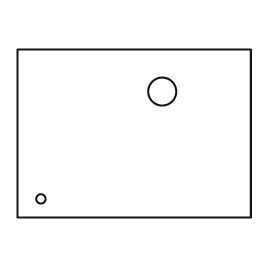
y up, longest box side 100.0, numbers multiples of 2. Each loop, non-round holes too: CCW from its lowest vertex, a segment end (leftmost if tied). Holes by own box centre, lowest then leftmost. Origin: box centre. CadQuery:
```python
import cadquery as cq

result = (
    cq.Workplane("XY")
    .moveTo(-50.0, -36.0)
    .lineTo(50.0, -36.0)
    .lineTo(50.0, 36.0)
    .lineTo(-50.0, 36.0)
    .close()
    .moveTo(-40.0, -28.0)
    .circle(2.0)
    .moveTo(12.0, 18.0)
    .circle(6.0)
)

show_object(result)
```